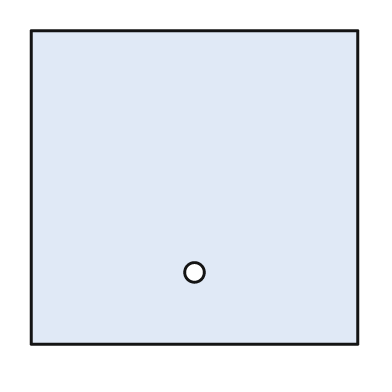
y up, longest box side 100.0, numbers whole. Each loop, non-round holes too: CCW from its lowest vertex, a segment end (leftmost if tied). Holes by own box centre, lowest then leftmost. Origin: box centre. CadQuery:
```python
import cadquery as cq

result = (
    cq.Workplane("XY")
    .moveTo(-50.0, -48.0)
    .lineTo(50.0, -48.0)
    .lineTo(50.0, 48.0)
    .lineTo(-50.0, 48.0)
    .close()
    .moveTo(0.0, -26.0)
    .circle(3.0)
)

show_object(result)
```